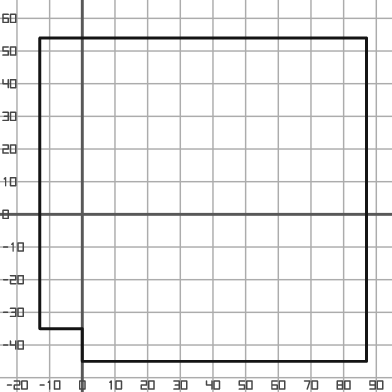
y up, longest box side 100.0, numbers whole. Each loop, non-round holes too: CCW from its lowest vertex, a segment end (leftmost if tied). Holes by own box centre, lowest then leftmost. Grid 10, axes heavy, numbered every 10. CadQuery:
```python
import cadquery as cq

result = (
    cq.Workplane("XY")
    .moveTo(0.0, -45.0)
    .lineTo(87.0, -45.0)
    .lineTo(87.0, 54.0)
    .lineTo(-13.0, 54.0)
    .lineTo(-13.0, -35.0)
    .lineTo(0.0, -35.0)
    .close()
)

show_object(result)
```